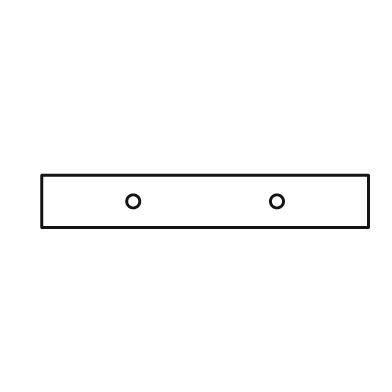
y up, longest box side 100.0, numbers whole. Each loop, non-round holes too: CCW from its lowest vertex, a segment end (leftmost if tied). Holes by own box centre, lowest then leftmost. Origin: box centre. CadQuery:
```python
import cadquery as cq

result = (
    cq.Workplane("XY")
    .moveTo(-50.0, -8.0)
    .lineTo(50.0, -8.0)
    .lineTo(50.0, 8.0)
    .lineTo(-50.0, 8.0)
    .close()
    .moveTo(-22.0, 0.0)
    .circle(2.0)
    .moveTo(22.0, 0.0)
    .circle(2.0)
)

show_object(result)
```